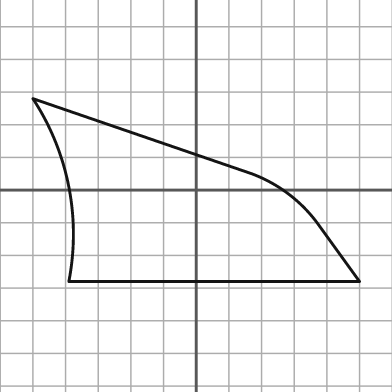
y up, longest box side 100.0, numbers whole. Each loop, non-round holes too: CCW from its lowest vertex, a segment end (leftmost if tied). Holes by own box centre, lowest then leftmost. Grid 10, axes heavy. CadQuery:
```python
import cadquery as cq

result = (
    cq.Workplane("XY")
    .moveTo(-39.0, -28.0)
    .lineTo(50.0, -28.0)
    .lineTo(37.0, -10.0)
    .threePointArc((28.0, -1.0), (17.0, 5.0))
    .lineTo(-50.0, 28.0)
    .threePointArc((-39.0, 1.0), (-39.0, -28.0))
    .close()
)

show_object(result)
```